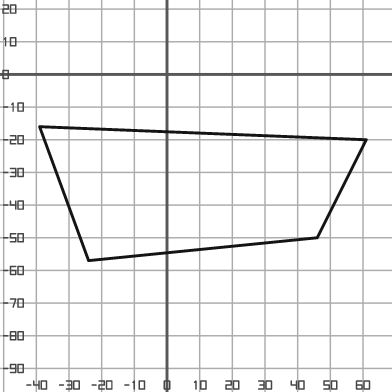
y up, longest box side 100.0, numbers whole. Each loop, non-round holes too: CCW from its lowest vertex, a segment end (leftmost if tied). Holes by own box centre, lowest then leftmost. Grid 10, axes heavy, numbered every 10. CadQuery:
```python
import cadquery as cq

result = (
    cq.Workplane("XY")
    .moveTo(-24.0, -57.0)
    .lineTo(46.0, -50.0)
    .lineTo(61.0, -20.0)
    .lineTo(-39.0, -16.0)
    .close()
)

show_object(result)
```